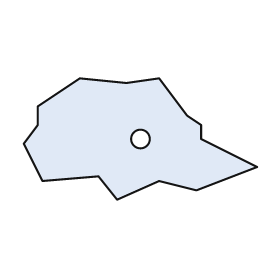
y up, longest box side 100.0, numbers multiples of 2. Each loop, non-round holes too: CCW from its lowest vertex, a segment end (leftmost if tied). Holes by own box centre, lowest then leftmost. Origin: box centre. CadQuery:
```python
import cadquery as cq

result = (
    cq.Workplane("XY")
    .moveTo(-10.0, -26.0)
    .lineTo(8.0, -18.0)
    .lineTo(24.0, -22.0)
    .lineTo(50.0, -12.0)
    .lineTo(26.0, 0.0)
    .lineTo(26.0, 6.0)
    .lineTo(20.0, 10.0)
    .lineTo(8.0, 26.0)
    .lineTo(-6.0, 24.0)
    .lineTo(-26.0, 26.0)
    .lineTo(-44.0, 14.0)
    .lineTo(-44.0, 6.0)
    .lineTo(-50.0, -2.0)
    .lineTo(-42.0, -18.0)
    .lineTo(-18.0, -16.0)
    .close()
    .moveTo(0.0, 0.0)
    .circle(4.0)
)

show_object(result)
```